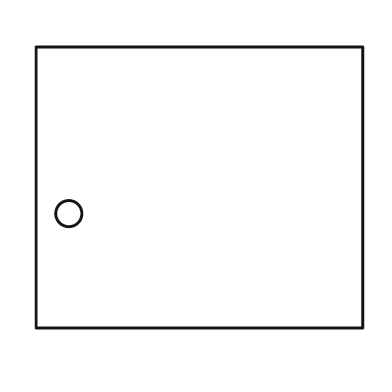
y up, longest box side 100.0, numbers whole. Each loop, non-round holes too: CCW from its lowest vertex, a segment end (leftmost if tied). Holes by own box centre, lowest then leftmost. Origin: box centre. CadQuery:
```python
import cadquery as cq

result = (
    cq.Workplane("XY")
    .moveTo(-50.0, -43.0)
    .lineTo(50.0, -43.0)
    .lineTo(50.0, 43.0)
    .lineTo(-50.0, 43.0)
    .close()
    .moveTo(-40.0, -8.0)
    .circle(4.0)
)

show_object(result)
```